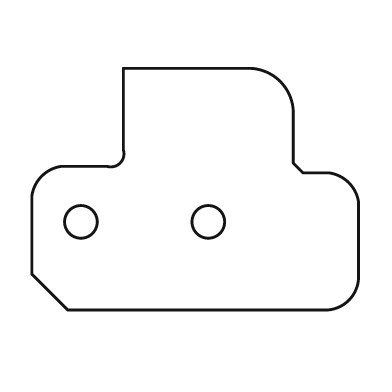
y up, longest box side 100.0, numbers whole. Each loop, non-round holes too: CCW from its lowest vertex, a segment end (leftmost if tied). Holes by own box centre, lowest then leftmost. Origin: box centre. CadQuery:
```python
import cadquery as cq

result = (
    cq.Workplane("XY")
    .moveTo(-39.0, -37.0)
    .lineTo(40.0, -37.0)
    .threePointArc((47.0, -34.0), (50.0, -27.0))
    .lineTo(50.0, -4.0)
    .threePointArc((47.0, 2.0), (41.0, 5.0))
    .lineTo(33.0, 5.0)
    .lineTo(30.0, 8.0)
    .lineTo(30.0, 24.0)
    .threePointArc((26.0, 33.0), (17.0, 37.0))
    .lineTo(-22.0, 37.0)
    .lineTo(-22.0, 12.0)
    .threePointArc((-23.0, 8.0), (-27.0, 7.0))
    .lineTo(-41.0, 7.0)
    .threePointArc((-47.0, 4.0), (-50.0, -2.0))
    .lineTo(-50.0, -26.0)
    .close()
    .moveTo(-35.0, -10.0)
    .circle(5.0)
    .moveTo(4.0, -10.0)
    .circle(5.0)
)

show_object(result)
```